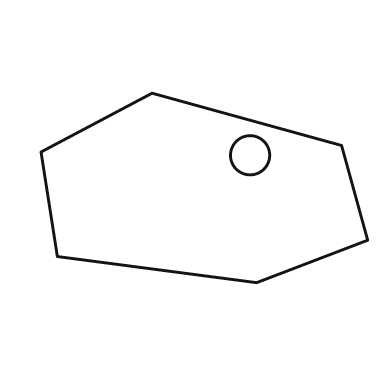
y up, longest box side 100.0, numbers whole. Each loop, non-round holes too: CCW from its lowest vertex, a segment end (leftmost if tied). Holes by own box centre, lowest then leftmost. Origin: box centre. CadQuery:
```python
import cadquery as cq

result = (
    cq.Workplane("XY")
    .moveTo(16.0, -29.0)
    .lineTo(50.0, -16.0)
    .lineTo(42.0, 13.0)
    .lineTo(-16.0, 29.0)
    .lineTo(-50.0, 11.0)
    .lineTo(-45.0, -21.0)
    .close()
    .moveTo(14.0, 10.0)
    .circle(6.0)
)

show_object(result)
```